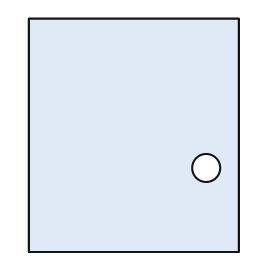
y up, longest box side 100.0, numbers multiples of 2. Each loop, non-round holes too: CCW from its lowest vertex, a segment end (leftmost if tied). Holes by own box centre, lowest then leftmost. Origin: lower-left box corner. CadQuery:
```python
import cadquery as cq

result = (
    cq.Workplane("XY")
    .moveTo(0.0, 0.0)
    .lineTo(90.0, 0.0)
    .lineTo(90.0, 100.0)
    .lineTo(0.0, 100.0)
    .close()
    .moveTo(76.0, 36.0)
    .circle(6.0)
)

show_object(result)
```